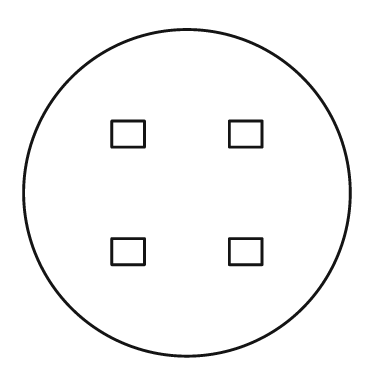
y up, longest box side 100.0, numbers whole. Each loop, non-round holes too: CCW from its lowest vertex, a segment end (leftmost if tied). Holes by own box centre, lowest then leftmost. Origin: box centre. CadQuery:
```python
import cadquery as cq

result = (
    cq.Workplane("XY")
    .moveTo(0.0, 0.0)
    .circle(50.0)
    .moveTo(-23.0, -22.0)
    .lineTo(-13.0, -22.0)
    .lineTo(-13.0, -14.0)
    .lineTo(-23.0, -14.0)
    .close()
    .moveTo(13.0, -22.0)
    .lineTo(23.0, -22.0)
    .lineTo(23.0, -14.0)
    .lineTo(13.0, -14.0)
    .close()
    .moveTo(-23.0, 14.0)
    .lineTo(-13.0, 14.0)
    .lineTo(-13.0, 22.0)
    .lineTo(-23.0, 22.0)
    .close()
    .moveTo(13.0, 14.0)
    .lineTo(23.0, 14.0)
    .lineTo(23.0, 22.0)
    .lineTo(13.0, 22.0)
    .close()
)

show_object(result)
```